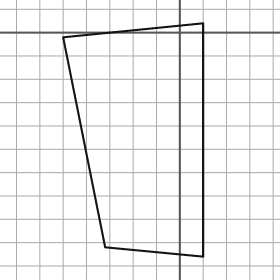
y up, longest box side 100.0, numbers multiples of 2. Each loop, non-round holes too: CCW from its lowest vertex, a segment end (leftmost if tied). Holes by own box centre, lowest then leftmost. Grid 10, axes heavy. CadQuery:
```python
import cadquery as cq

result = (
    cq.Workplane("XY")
    .moveTo(10.0, -96.0)
    .lineTo(10.0, 4.0)
    .lineTo(-50.0, -2.0)
    .lineTo(-32.0, -92.0)
    .close()
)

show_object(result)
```